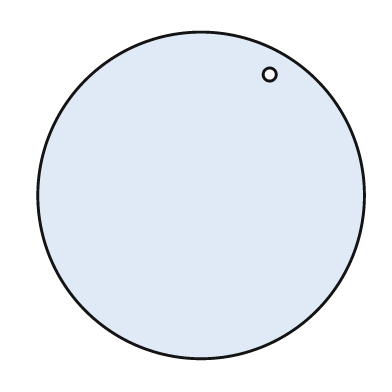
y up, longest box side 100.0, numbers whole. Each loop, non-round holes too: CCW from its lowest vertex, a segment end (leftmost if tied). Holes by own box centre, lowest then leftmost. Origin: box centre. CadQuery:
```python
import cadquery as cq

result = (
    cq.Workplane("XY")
    .moveTo(0.0, 0.0)
    .circle(50.0)
    .moveTo(21.0, 37.0)
    .circle(2.0)
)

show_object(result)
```